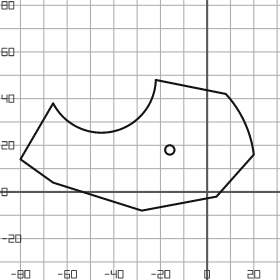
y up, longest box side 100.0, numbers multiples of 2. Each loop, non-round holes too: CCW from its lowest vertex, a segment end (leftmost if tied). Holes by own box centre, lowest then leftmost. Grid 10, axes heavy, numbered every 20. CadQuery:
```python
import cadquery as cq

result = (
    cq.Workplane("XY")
    .moveTo(-28.0, -8.0)
    .lineTo(4.0, -2.0)
    .lineTo(20.0, 16.0)
    .threePointArc((16.0, 30.0), (8.0, 42.0))
    .lineTo(-22.0, 48.0)
    .threePointArc((-40.0, 26.0), (-66.0, 38.0))
    .lineTo(-80.0, 14.0)
    .lineTo(-66.0, 4.0)
    .close()
    .moveTo(-16.0, 18.0)
    .circle(2.0)
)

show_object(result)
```